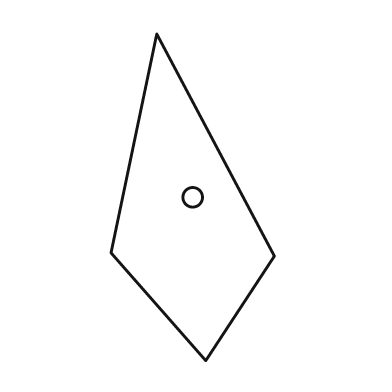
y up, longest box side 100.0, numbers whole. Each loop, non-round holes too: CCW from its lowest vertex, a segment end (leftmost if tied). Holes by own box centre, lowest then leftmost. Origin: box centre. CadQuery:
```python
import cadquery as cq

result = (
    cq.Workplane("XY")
    .moveTo(4.0, -50.0)
    .lineTo(25.0, -18.0)
    .lineTo(-11.0, 50.0)
    .lineTo(-25.0, -17.0)
    .close()
    .moveTo(0.0, 0.0)
    .circle(3.0)
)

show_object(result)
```